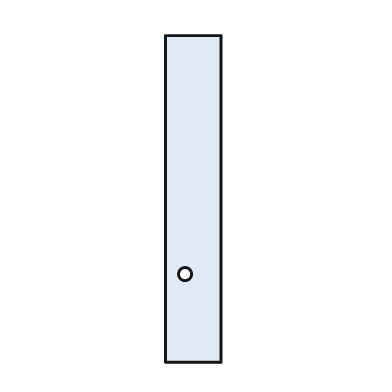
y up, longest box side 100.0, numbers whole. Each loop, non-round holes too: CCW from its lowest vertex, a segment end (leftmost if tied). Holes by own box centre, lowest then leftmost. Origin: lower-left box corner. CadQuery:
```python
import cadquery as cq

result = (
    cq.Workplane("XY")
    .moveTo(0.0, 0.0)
    .lineTo(17.0, 0.0)
    .lineTo(17.0, 100.0)
    .lineTo(0.0, 100.0)
    .close()
    .moveTo(6.0, 27.0)
    .circle(2.0)
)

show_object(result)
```